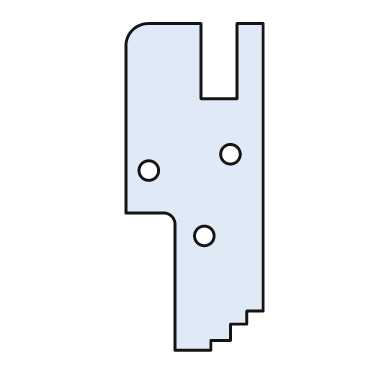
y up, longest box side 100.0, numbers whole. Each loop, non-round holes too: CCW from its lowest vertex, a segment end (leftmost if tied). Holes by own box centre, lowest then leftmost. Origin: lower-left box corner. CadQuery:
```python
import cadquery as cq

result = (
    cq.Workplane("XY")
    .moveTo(15.0, 0.0)
    .lineTo(26.0, 0.0)
    .lineTo(26.0, 3.0)
    .lineTo(32.0, 3.0)
    .lineTo(32.0, 8.0)
    .lineTo(37.0, 8.0)
    .lineTo(37.0, 12.0)
    .lineTo(42.0, 12.0)
    .lineTo(42.0, 100.0)
    .lineTo(34.0, 100.0)
    .lineTo(34.0, 77.0)
    .lineTo(23.0, 77.0)
    .lineTo(23.0, 100.0)
    .lineTo(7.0, 100.0)
    .threePointArc((2.0, 98.0), (0.0, 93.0))
    .lineTo(0.0, 42.0)
    .lineTo(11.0, 42.0)
    .threePointArc((14.0, 41.0), (15.0, 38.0))
    .close()
    .moveTo(24.0, 35.0)
    .circle(3.0)
    .moveTo(7.0, 55.0)
    .circle(3.0)
    .moveTo(32.0, 60.0)
    .circle(3.0)
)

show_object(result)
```